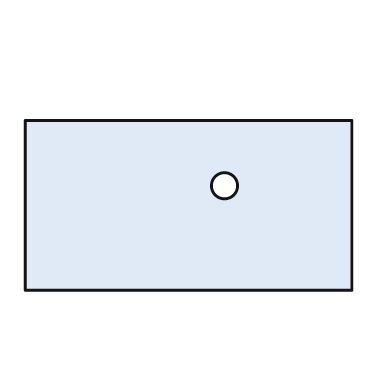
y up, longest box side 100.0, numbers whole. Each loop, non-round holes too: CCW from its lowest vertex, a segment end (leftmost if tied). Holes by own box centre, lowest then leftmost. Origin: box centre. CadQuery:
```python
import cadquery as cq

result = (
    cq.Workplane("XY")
    .moveTo(-50.0, -26.0)
    .lineTo(50.0, -26.0)
    .lineTo(50.0, 26.0)
    .lineTo(-50.0, 26.0)
    .close()
    .moveTo(11.0, 6.0)
    .circle(4.0)
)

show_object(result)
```